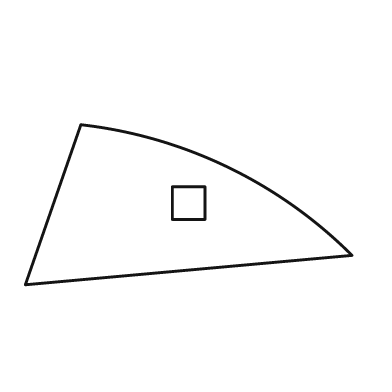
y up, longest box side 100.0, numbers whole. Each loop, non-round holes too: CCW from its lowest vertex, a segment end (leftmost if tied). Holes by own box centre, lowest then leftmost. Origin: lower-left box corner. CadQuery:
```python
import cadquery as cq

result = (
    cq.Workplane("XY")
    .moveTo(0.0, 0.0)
    .lineTo(100.0, 9.0)
    .threePointArc((62.0, 36.0), (17.0, 49.0))
    .close()
    .moveTo(45.0, 20.0)
    .lineTo(55.0, 20.0)
    .lineTo(55.0, 30.0)
    .lineTo(45.0, 30.0)
    .close()
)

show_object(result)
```